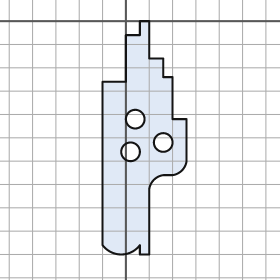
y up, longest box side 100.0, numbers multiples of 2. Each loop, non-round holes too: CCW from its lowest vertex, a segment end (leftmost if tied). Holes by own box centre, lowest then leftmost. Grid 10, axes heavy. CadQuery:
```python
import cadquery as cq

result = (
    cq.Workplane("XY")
    .moveTo(6.0, -100.0)
    .lineTo(10.0, -100.0)
    .lineTo(10.0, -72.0)
    .threePointArc((12.0, -68.0), (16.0, -66.0))
    .lineTo(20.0, -66.0)
    .threePointArc((24.0, -64.0), (26.0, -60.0))
    .lineTo(26.0, -42.0)
    .lineTo(20.0, -42.0)
    .lineTo(20.0, -24.0)
    .lineTo(16.0, -24.0)
    .lineTo(16.0, -16.0)
    .lineTo(10.0, -16.0)
    .lineTo(10.0, 0.0)
    .lineTo(6.0, 0.0)
    .lineTo(6.0, -6.0)
    .lineTo(0.0, -6.0)
    .lineTo(0.0, -26.0)
    .lineTo(-10.0, -26.0)
    .lineTo(-10.0, -96.0)
    .threePointArc((-2.0, -100.0), (6.0, -96.0))
    .close()
    .moveTo(2.0, -56.0)
    .circle(4.0)
    .moveTo(16.0, -52.0)
    .circle(4.0)
    .moveTo(4.0, -42.0)
    .circle(4.0)
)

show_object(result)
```